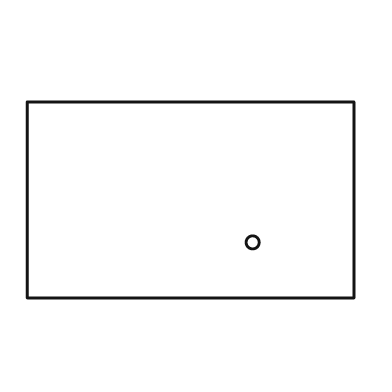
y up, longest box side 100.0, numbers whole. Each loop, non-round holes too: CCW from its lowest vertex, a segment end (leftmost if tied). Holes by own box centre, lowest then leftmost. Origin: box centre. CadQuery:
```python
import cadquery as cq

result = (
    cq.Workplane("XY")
    .moveTo(-50.0, -30.0)
    .lineTo(50.0, -30.0)
    .lineTo(50.0, 30.0)
    .lineTo(-50.0, 30.0)
    .close()
    .moveTo(19.0, -13.0)
    .circle(2.0)
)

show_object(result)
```